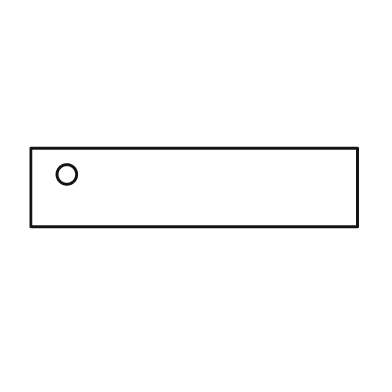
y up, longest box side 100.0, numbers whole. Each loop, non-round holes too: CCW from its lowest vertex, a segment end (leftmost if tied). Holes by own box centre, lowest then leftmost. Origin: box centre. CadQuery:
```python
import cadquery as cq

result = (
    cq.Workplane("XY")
    .moveTo(-50.0, -12.0)
    .lineTo(50.0, -12.0)
    .lineTo(50.0, 12.0)
    .lineTo(-50.0, 12.0)
    .close()
    .moveTo(-39.0, 4.0)
    .circle(3.0)
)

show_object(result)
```